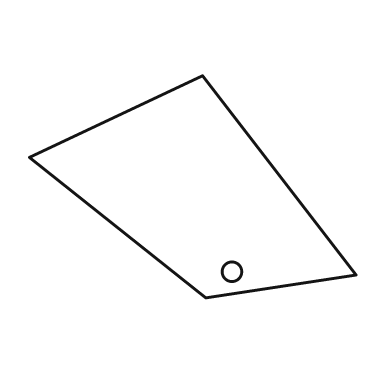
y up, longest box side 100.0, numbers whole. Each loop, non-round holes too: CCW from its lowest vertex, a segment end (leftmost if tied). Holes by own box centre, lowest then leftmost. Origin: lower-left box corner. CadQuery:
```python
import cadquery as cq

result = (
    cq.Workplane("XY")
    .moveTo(54.0, 0.0)
    .lineTo(100.0, 7.0)
    .lineTo(53.0, 68.0)
    .lineTo(0.0, 43.0)
    .close()
    .moveTo(62.0, 8.0)
    .circle(3.0)
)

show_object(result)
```